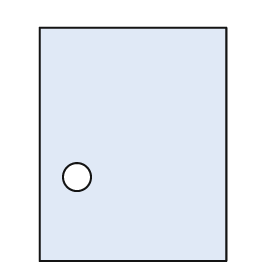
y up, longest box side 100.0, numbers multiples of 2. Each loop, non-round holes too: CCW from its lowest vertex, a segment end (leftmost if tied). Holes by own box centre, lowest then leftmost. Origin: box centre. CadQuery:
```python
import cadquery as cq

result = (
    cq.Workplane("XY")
    .moveTo(-40.0, -50.0)
    .lineTo(40.0, -50.0)
    .lineTo(40.0, 50.0)
    .lineTo(-40.0, 50.0)
    .close()
    .moveTo(-24.0, -14.0)
    .circle(6.0)
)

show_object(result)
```